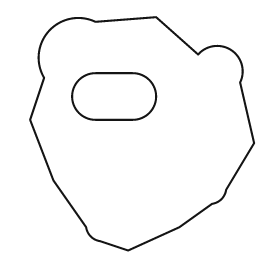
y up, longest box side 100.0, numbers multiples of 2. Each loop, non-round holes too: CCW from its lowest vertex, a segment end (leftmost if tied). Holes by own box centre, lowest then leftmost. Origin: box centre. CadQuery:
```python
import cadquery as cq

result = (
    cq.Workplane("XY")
    .moveTo(-6.0, -50.0)
    .lineTo(16.0, -40.0)
    .lineTo(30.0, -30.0)
    .threePointArc((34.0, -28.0), (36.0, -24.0))
    .lineTo(48.0, -4.0)
    .lineTo(42.0, 22.0)
    .threePointArc((38.0, 36.0), (24.0, 34.0))
    .lineTo(6.0, 50.0)
    .lineTo(-20.0, 48.0)
    .threePointArc((-40.0, 44.0), (-42.0, 24.0))
    .lineTo(-48.0, 6.0)
    .lineTo(-38.0, -20.0)
    .lineTo(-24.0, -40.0)
    .threePointArc((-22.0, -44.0), (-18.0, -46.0))
    .close()
    .moveTo(-20.0, 6.0)
    .lineTo(-4.0, 6.0)
    .threePointArc((6.0, 16.0), (-4.0, 26.0))
    .lineTo(-20.0, 26.0)
    .threePointArc((-30.0, 16.0), (-20.0, 6.0))
    .close()
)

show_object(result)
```